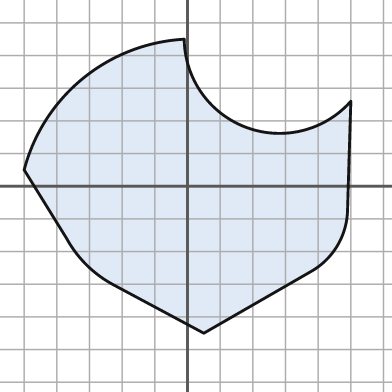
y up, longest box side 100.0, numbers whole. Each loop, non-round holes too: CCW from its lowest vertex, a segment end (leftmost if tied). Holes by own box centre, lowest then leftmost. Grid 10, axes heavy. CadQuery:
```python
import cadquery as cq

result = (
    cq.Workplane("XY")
    .moveTo(5.0, -45.0)
    .lineTo(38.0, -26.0)
    .threePointArc((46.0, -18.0), (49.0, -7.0))
    .lineTo(50.0, 26.0)
    .threePointArc((18.0, 18.0), (-1.0, 45.0))
    .threePointArc((-32.0, 33.0), (-50.0, 5.0))
    .lineTo(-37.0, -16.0)
    .threePointArc((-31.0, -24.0), (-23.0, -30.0))
    .close()
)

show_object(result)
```